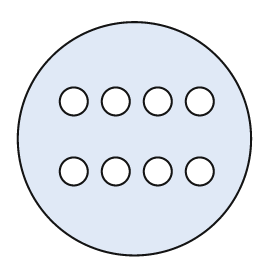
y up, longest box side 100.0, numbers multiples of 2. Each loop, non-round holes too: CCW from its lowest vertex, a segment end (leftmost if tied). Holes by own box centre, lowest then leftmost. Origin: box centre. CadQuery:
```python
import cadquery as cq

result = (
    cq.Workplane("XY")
    .moveTo(0.0, 0.0)
    .circle(50.0)
    .moveTo(-26.0, -14.0)
    .circle(6.0)
    .moveTo(-8.0, -14.0)
    .circle(6.0)
    .moveTo(10.0, -14.0)
    .circle(6.0)
    .moveTo(28.0, -14.0)
    .circle(6.0)
    .moveTo(-26.0, 16.0)
    .circle(6.0)
    .moveTo(-8.0, 16.0)
    .circle(6.0)
    .moveTo(10.0, 16.0)
    .circle(6.0)
    .moveTo(28.0, 16.0)
    .circle(6.0)
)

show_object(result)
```